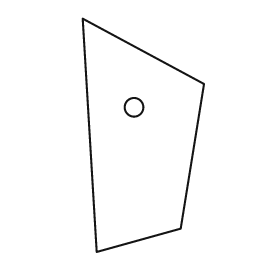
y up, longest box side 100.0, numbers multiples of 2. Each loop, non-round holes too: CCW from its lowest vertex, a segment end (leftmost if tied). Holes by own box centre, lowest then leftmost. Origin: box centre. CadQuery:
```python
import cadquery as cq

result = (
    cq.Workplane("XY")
    .moveTo(-20.0, -50.0)
    .lineTo(16.0, -40.0)
    .lineTo(26.0, 22.0)
    .lineTo(-26.0, 50.0)
    .close()
    .moveTo(-4.0, 12.0)
    .circle(4.0)
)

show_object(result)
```